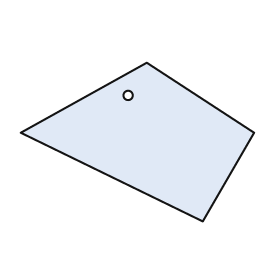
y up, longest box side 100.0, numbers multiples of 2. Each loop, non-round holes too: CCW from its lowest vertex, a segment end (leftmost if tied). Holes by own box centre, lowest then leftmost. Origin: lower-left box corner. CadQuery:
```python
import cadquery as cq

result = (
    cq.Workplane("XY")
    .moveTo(78.0, 0.0)
    .lineTo(100.0, 38.0)
    .lineTo(54.0, 68.0)
    .lineTo(0.0, 38.0)
    .close()
    .moveTo(46.0, 54.0)
    .circle(2.0)
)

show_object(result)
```